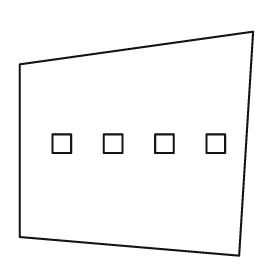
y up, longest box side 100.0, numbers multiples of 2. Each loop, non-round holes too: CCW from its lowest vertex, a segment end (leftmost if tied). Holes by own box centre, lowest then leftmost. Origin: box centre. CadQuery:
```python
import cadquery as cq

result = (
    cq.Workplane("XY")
    .moveTo(44.0, -48.0)
    .lineTo(50.0, 48.0)
    .lineTo(-50.0, 34.0)
    .lineTo(-50.0, -40.0)
    .close()
    .moveTo(-36.0, -4.0)
    .lineTo(-28.0, -4.0)
    .lineTo(-28.0, 4.0)
    .lineTo(-36.0, 4.0)
    .close()
    .moveTo(-14.0, -4.0)
    .lineTo(-6.0, -4.0)
    .lineTo(-6.0, 4.0)
    .lineTo(-14.0, 4.0)
    .close()
    .moveTo(8.0, -4.0)
    .lineTo(16.0, -4.0)
    .lineTo(16.0, 4.0)
    .lineTo(8.0, 4.0)
    .close()
    .moveTo(30.0, -4.0)
    .lineTo(38.0, -4.0)
    .lineTo(38.0, 4.0)
    .lineTo(30.0, 4.0)
    .close()
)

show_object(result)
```